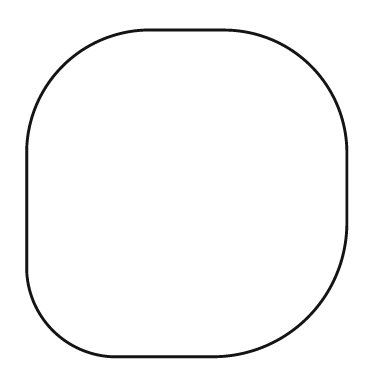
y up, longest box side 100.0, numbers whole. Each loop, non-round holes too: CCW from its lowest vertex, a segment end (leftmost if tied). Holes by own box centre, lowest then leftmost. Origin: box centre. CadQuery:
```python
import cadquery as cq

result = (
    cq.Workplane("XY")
    .moveTo(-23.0, -50.0)
    .lineTo(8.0, -50.0)
    .threePointArc((37.0, -38.0), (49.0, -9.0))
    .lineTo(49.0, 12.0)
    .threePointArc((38.0, 39.0), (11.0, 50.0))
    .lineTo(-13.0, 50.0)
    .threePointArc((-38.0, 39.0), (-49.0, 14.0))
    .lineTo(-49.0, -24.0)
    .threePointArc((-41.0, -42.0), (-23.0, -50.0))
    .close()
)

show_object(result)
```